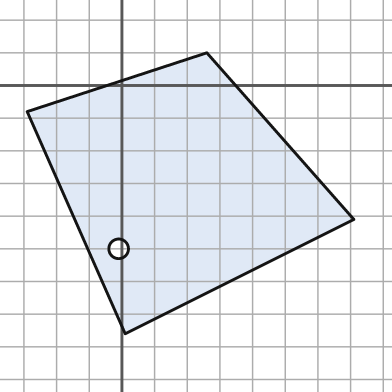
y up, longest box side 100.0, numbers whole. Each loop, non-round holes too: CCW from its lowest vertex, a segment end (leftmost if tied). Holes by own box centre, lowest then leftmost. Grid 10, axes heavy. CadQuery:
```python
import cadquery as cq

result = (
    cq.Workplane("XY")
    .moveTo(1.0, -76.0)
    .lineTo(71.0, -41.0)
    .lineTo(26.0, 10.0)
    .lineTo(-29.0, -8.0)
    .close()
    .moveTo(-1.0, -50.0)
    .circle(3.0)
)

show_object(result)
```